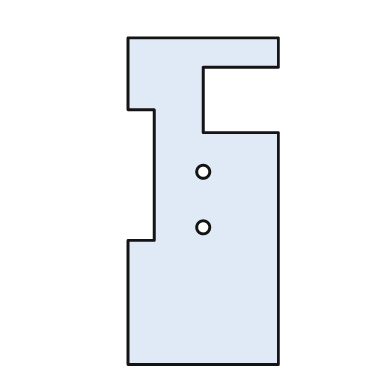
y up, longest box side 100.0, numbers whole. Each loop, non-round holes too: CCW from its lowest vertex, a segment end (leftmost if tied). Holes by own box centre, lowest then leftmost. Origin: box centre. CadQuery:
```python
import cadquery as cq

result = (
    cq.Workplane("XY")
    .moveTo(-23.0, -50.0)
    .lineTo(23.0, -50.0)
    .lineTo(23.0, 21.0)
    .lineTo(0.0, 21.0)
    .lineTo(0.0, 41.0)
    .lineTo(23.0, 41.0)
    .lineTo(23.0, 50.0)
    .lineTo(-23.0, 50.0)
    .lineTo(-23.0, 28.0)
    .lineTo(-15.0, 28.0)
    .lineTo(-15.0, -12.0)
    .lineTo(-23.0, -12.0)
    .close()
    .moveTo(0.0, -8.0)
    .circle(2.0)
    .moveTo(0.0, 9.0)
    .circle(2.0)
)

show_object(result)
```